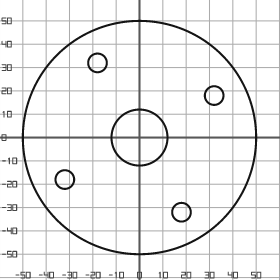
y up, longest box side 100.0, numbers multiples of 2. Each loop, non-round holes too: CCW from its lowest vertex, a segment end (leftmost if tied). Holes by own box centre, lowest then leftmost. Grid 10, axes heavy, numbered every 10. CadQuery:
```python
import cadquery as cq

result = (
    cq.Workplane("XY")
    .moveTo(0.0, 0.0)
    .circle(50.0)
    .moveTo(18.0, -32.0)
    .circle(4.0)
    .moveTo(-32.0, -18.0)
    .circle(4.0)
    .moveTo(0.0, 0.0)
    .circle(12.0)
    .moveTo(32.0, 18.0)
    .circle(4.0)
    .moveTo(-18.0, 32.0)
    .circle(4.0)
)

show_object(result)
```